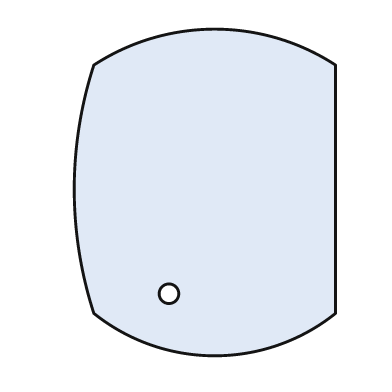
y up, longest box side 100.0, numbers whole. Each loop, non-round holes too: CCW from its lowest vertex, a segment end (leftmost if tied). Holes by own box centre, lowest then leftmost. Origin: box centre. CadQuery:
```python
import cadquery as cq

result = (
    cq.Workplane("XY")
    .moveTo(-34.0, -37.0)
    .threePointArc((3.0, -50.0), (40.0, -37.0))
    .lineTo(40.0, 39.0)
    .threePointArc((3.0, 50.0), (-34.0, 39.0))
    .threePointArc((-40.0, 1.0), (-34.0, -37.0))
    .close()
    .moveTo(-11.0, -31.0)
    .circle(3.0)
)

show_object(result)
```